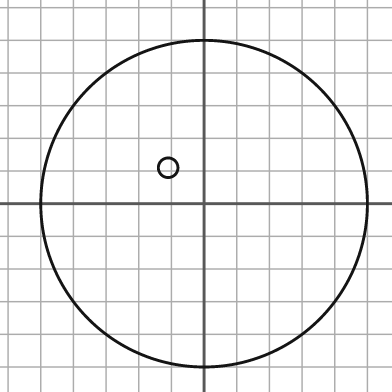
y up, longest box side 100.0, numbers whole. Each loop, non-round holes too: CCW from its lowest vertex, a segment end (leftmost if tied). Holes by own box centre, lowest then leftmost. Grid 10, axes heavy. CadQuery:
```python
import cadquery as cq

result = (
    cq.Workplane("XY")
    .moveTo(0.0, 0.0)
    .circle(50.0)
    .moveTo(-11.0, 11.0)
    .circle(3.0)
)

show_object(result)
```